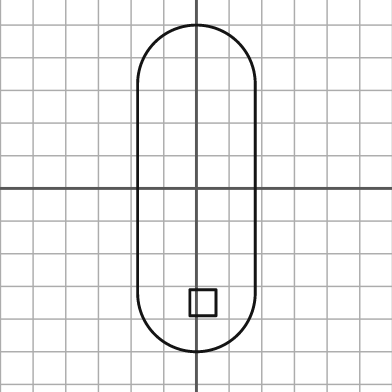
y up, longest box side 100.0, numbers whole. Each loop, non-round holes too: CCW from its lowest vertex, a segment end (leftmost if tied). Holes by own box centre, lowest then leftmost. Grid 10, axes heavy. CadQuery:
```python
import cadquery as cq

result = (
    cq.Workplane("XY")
    .moveTo(-18.0, -32.0)
    .threePointArc((0.0, -50.0), (18.0, -32.0))
    .lineTo(18.0, 32.0)
    .threePointArc((0.0, 50.0), (-18.0, 32.0))
    .close()
    .moveTo(-2.0, -39.0)
    .lineTo(6.0, -39.0)
    .lineTo(6.0, -31.0)
    .lineTo(-2.0, -31.0)
    .close()
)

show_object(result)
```